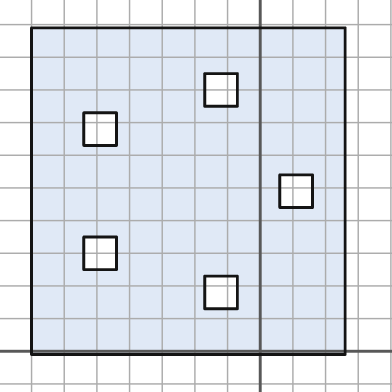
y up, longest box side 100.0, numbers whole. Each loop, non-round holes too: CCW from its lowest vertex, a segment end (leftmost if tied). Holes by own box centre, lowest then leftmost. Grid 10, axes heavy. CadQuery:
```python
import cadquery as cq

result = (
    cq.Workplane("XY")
    .moveTo(-70.0, -1.0)
    .lineTo(26.0, -1.0)
    .lineTo(26.0, 99.0)
    .lineTo(-70.0, 99.0)
    .close()
    .moveTo(-17.0, 13.0)
    .lineTo(-7.0, 13.0)
    .lineTo(-7.0, 23.0)
    .lineTo(-17.0, 23.0)
    .close()
    .moveTo(-54.0, 25.0)
    .lineTo(-44.0, 25.0)
    .lineTo(-44.0, 35.0)
    .lineTo(-54.0, 35.0)
    .close()
    .moveTo(6.0, 44.0)
    .lineTo(16.0, 44.0)
    .lineTo(16.0, 54.0)
    .lineTo(6.0, 54.0)
    .close()
    .moveTo(-54.0, 63.0)
    .lineTo(-44.0, 63.0)
    .lineTo(-44.0, 73.0)
    .lineTo(-54.0, 73.0)
    .close()
    .moveTo(-17.0, 75.0)
    .lineTo(-7.0, 75.0)
    .lineTo(-7.0, 85.0)
    .lineTo(-17.0, 85.0)
    .close()
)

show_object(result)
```